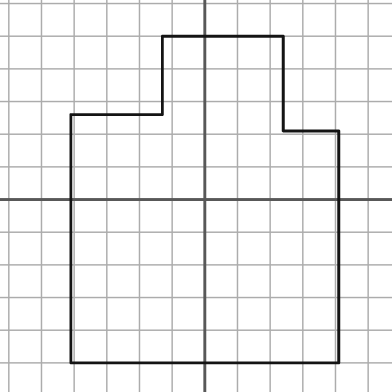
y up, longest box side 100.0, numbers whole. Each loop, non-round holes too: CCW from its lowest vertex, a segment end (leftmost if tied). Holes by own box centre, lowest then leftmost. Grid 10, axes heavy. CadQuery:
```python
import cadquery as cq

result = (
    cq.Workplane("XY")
    .moveTo(-41.0, -50.0)
    .lineTo(41.0, -50.0)
    .lineTo(41.0, 21.0)
    .lineTo(24.0, 21.0)
    .lineTo(24.0, 50.0)
    .lineTo(-13.0, 50.0)
    .lineTo(-13.0, 26.0)
    .lineTo(-41.0, 26.0)
    .close()
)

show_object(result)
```